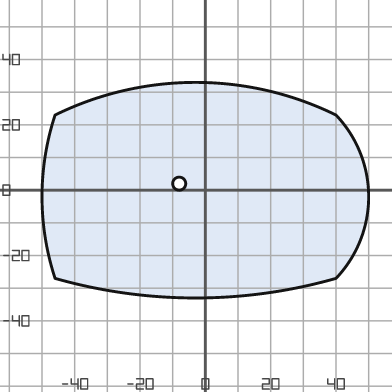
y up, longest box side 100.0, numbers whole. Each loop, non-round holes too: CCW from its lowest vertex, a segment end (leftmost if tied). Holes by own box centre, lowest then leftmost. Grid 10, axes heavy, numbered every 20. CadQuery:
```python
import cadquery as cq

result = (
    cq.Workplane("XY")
    .moveTo(-46.0, -27.0)
    .threePointArc((-3.0, -33.0), (40.0, -27.0))
    .threePointArc((50.0, -2.0), (40.0, 23.0))
    .threePointArc((-3.0, 33.0), (-46.0, 23.0))
    .threePointArc((-50.0, -2.0), (-46.0, -27.0))
    .close()
    .moveTo(-8.0, 2.0)
    .circle(2.0)
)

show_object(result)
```